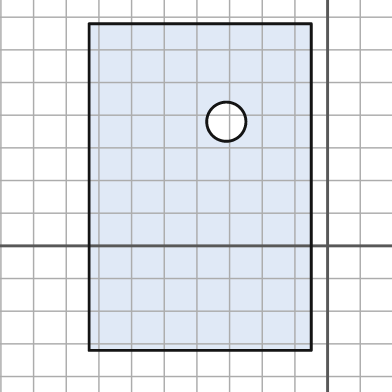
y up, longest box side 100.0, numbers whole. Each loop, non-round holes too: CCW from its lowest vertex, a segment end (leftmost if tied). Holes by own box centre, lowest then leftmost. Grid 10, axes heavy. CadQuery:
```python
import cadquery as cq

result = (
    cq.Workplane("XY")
    .moveTo(-73.0, -32.0)
    .lineTo(-5.0, -32.0)
    .lineTo(-5.0, 68.0)
    .lineTo(-73.0, 68.0)
    .close()
    .moveTo(-31.0, 38.0)
    .circle(6.0)
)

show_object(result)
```